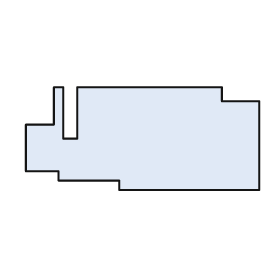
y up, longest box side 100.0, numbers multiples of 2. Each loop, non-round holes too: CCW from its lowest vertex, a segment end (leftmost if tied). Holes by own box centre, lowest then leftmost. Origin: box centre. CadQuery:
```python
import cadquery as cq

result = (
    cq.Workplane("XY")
    .moveTo(-10.0, -22.0)
    .lineTo(50.0, -22.0)
    .lineTo(50.0, 16.0)
    .lineTo(34.0, 16.0)
    .lineTo(34.0, 22.0)
    .lineTo(-28.0, 22.0)
    .lineTo(-28.0, 0.0)
    .lineTo(-34.0, 0.0)
    .lineTo(-34.0, 22.0)
    .lineTo(-38.0, 22.0)
    .lineTo(-38.0, 6.0)
    .lineTo(-50.0, 6.0)
    .lineTo(-50.0, -14.0)
    .lineTo(-36.0, -14.0)
    .lineTo(-36.0, -18.0)
    .lineTo(-10.0, -18.0)
    .close()
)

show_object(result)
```